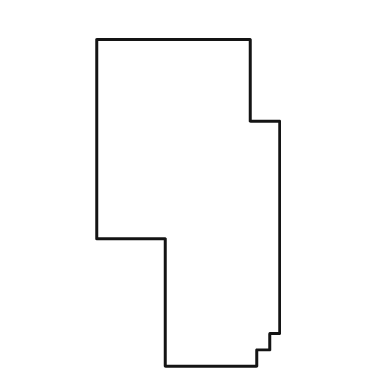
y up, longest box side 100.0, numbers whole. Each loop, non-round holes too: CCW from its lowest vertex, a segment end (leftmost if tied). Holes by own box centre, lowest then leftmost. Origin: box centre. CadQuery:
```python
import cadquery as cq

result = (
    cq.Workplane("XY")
    .moveTo(-7.0, -50.0)
    .lineTo(21.0, -50.0)
    .lineTo(21.0, -45.0)
    .lineTo(25.0, -45.0)
    .lineTo(25.0, -40.0)
    .lineTo(28.0, -40.0)
    .lineTo(28.0, 25.0)
    .lineTo(19.0, 25.0)
    .lineTo(19.0, 50.0)
    .lineTo(-28.0, 50.0)
    .lineTo(-28.0, -11.0)
    .lineTo(-7.0, -11.0)
    .close()
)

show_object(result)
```